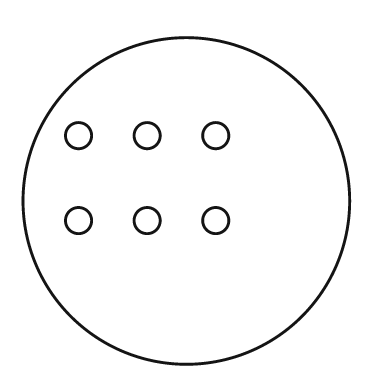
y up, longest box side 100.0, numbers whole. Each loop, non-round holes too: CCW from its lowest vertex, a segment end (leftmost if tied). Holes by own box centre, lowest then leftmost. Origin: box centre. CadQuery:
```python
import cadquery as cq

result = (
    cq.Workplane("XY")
    .moveTo(0.0, 0.0)
    .circle(50.0)
    .moveTo(-33.0, -6.0)
    .circle(4.0)
    .moveTo(-12.0, -6.0)
    .circle(4.0)
    .moveTo(9.0, -6.0)
    .circle(4.0)
    .moveTo(-33.0, 20.0)
    .circle(4.0)
    .moveTo(-12.0, 20.0)
    .circle(4.0)
    .moveTo(9.0, 20.0)
    .circle(4.0)
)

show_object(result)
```